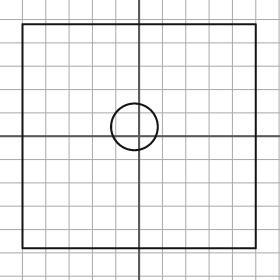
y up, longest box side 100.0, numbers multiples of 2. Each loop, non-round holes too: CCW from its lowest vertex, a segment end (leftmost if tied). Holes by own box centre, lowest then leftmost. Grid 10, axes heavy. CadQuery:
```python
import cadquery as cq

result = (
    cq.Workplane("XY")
    .moveTo(-50.0, -48.0)
    .lineTo(50.0, -48.0)
    .lineTo(50.0, 48.0)
    .lineTo(-50.0, 48.0)
    .close()
    .moveTo(-2.0, 4.0)
    .circle(10.0)
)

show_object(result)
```